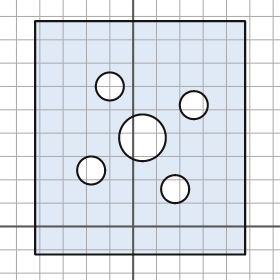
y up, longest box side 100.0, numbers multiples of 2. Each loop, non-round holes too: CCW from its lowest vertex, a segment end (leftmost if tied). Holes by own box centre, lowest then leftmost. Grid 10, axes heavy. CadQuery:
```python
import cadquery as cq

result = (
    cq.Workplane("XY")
    .moveTo(-42.0, -12.0)
    .lineTo(48.0, -12.0)
    .lineTo(48.0, 88.0)
    .lineTo(-42.0, 88.0)
    .close()
    .moveTo(18.0, 16.0)
    .circle(6.0)
    .moveTo(-18.0, 24.0)
    .circle(6.0)
    .moveTo(4.0, 38.0)
    .circle(10.0)
    .moveTo(26.0, 52.0)
    .circle(6.0)
    .moveTo(-10.0, 60.0)
    .circle(6.0)
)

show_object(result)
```